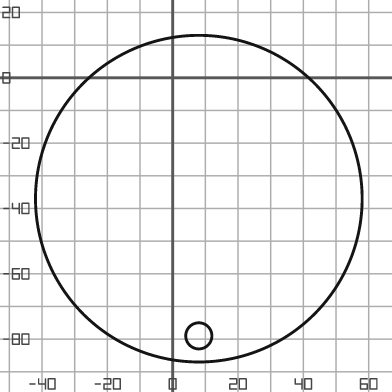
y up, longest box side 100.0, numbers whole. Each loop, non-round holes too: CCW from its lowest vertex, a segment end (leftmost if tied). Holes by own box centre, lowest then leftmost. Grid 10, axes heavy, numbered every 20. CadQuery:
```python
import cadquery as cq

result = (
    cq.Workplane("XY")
    .moveTo(8.0, -37.0)
    .circle(50.0)
    .moveTo(8.0, -79.0)
    .circle(4.0)
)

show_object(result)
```